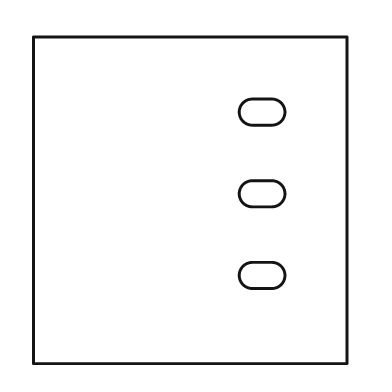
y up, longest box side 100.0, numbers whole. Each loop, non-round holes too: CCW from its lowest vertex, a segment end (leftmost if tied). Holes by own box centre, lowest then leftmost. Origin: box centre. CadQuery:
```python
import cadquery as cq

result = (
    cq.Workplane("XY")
    .moveTo(-48.0, -50.0)
    .lineTo(48.0, -50.0)
    .lineTo(48.0, 50.0)
    .lineTo(-48.0, 50.0)
    .close()
    .moveTo(19.0, -27.0)
    .lineTo(25.0, -27.0)
    .threePointArc((29.0, -23.0), (25.0, -19.0))
    .lineTo(19.0, -19.0)
    .threePointArc((15.0, -23.0), (19.0, -27.0))
    .close()
    .moveTo(19.0, -2.0)
    .lineTo(25.0, -2.0)
    .threePointArc((29.0, 2.0), (25.0, 6.0))
    .lineTo(19.0, 6.0)
    .threePointArc((15.0, 2.0), (19.0, -2.0))
    .close()
    .moveTo(19.0, 23.0)
    .lineTo(25.0, 23.0)
    .threePointArc((29.0, 27.0), (25.0, 31.0))
    .lineTo(19.0, 31.0)
    .threePointArc((15.0, 27.0), (19.0, 23.0))
    .close()
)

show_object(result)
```